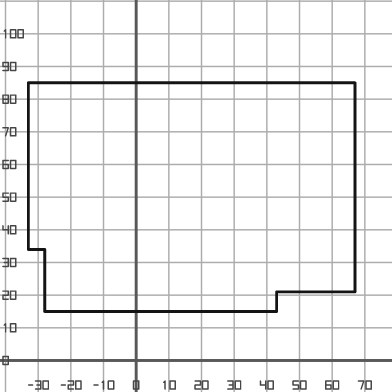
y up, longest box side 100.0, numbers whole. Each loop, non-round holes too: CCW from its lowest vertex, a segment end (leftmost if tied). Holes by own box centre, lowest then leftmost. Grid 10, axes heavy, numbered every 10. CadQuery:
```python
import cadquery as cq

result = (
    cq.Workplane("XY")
    .moveTo(-28.0, 15.0)
    .lineTo(43.0, 15.0)
    .lineTo(43.0, 21.0)
    .lineTo(67.0, 21.0)
    .lineTo(67.0, 85.0)
    .lineTo(-33.0, 85.0)
    .lineTo(-33.0, 34.0)
    .lineTo(-28.0, 34.0)
    .close()
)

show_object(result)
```